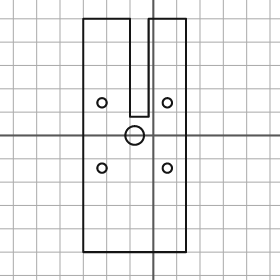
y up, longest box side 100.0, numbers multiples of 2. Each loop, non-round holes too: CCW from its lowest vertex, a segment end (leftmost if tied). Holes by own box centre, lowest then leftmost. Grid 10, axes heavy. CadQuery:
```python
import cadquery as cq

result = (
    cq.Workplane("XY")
    .moveTo(-30.0, -50.0)
    .lineTo(14.0, -50.0)
    .lineTo(14.0, 50.0)
    .lineTo(-2.0, 50.0)
    .lineTo(-2.0, 8.0)
    .lineTo(-10.0, 8.0)
    .lineTo(-10.0, 50.0)
    .lineTo(-30.0, 50.0)
    .close()
    .moveTo(-22.0, -14.0)
    .circle(2.0)
    .moveTo(6.0, -14.0)
    .circle(2.0)
    .moveTo(-8.0, 0.0)
    .circle(4.0)
    .moveTo(-22.0, 14.0)
    .circle(2.0)
    .moveTo(6.0, 14.0)
    .circle(2.0)
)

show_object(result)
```